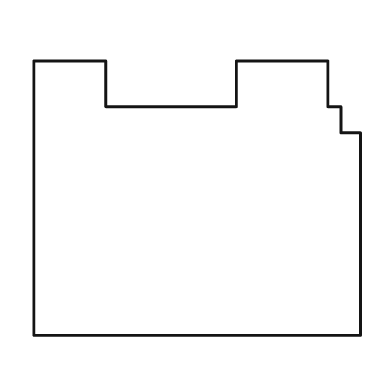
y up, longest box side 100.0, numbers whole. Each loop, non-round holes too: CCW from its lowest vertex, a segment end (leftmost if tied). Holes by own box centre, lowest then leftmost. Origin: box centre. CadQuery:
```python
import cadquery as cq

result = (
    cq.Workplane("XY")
    .moveTo(-50.0, -42.0)
    .lineTo(50.0, -42.0)
    .lineTo(50.0, 20.0)
    .lineTo(44.0, 20.0)
    .lineTo(44.0, 28.0)
    .lineTo(40.0, 28.0)
    .lineTo(40.0, 42.0)
    .lineTo(12.0, 42.0)
    .lineTo(12.0, 28.0)
    .lineTo(-28.0, 28.0)
    .lineTo(-28.0, 42.0)
    .lineTo(-50.0, 42.0)
    .close()
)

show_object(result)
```